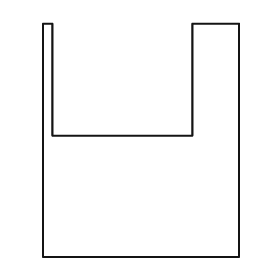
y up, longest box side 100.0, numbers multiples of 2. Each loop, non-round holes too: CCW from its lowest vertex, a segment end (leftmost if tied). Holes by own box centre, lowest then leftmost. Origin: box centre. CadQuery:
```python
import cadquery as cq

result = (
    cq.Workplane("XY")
    .moveTo(-42.0, -50.0)
    .lineTo(42.0, -50.0)
    .lineTo(42.0, 50.0)
    .lineTo(22.0, 50.0)
    .lineTo(22.0, 2.0)
    .lineTo(-38.0, 2.0)
    .lineTo(-38.0, 50.0)
    .lineTo(-42.0, 50.0)
    .close()
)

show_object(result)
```